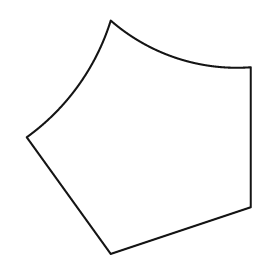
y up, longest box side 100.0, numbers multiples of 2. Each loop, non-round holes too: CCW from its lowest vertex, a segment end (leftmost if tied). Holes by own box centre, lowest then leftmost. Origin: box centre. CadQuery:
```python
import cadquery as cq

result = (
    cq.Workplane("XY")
    .moveTo(-12.0, -50.0)
    .lineTo(48.0, -30.0)
    .lineTo(48.0, 30.0)
    .threePointArc((16.0, 34.0), (-12.0, 50.0))
    .threePointArc((-26.0, 22.0), (-48.0, 0.0))
    .close()
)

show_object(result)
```